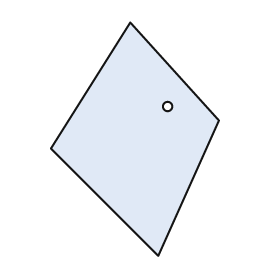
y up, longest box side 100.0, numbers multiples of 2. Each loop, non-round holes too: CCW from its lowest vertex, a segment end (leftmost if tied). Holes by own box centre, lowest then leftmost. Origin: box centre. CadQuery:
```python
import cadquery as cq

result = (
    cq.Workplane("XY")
    .moveTo(10.0, -50.0)
    .lineTo(36.0, 8.0)
    .lineTo(-2.0, 50.0)
    .lineTo(-36.0, -4.0)
    .close()
    .moveTo(14.0, 14.0)
    .circle(2.0)
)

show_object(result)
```